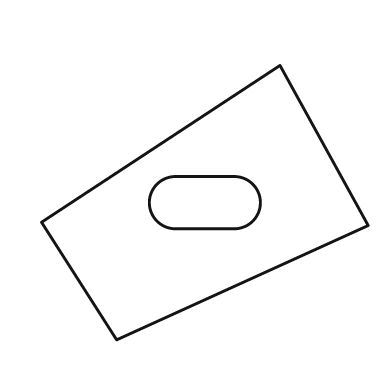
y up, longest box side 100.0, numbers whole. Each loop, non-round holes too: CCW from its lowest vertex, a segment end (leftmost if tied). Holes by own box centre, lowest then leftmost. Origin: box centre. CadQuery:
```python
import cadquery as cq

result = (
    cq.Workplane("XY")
    .moveTo(-27.0, -42.0)
    .lineTo(50.0, -7.0)
    .lineTo(23.0, 42.0)
    .lineTo(-50.0, -6.0)
    .close()
    .moveTo(-9.0, -8.0)
    .lineTo(9.0, -8.0)
    .threePointArc((17.0, 0.0), (9.0, 8.0))
    .lineTo(-9.0, 8.0)
    .threePointArc((-17.0, 0.0), (-9.0, -8.0))
    .close()
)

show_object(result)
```